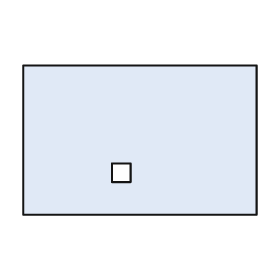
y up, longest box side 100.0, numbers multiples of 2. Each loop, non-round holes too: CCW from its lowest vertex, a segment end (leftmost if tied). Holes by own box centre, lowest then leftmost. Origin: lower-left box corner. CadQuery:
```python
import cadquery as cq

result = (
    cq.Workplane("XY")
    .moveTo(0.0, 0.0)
    .lineTo(100.0, 0.0)
    .lineTo(100.0, 64.0)
    .lineTo(0.0, 64.0)
    .close()
    .moveTo(38.0, 14.0)
    .lineTo(46.0, 14.0)
    .lineTo(46.0, 22.0)
    .lineTo(38.0, 22.0)
    .close()
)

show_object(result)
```